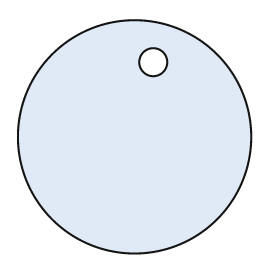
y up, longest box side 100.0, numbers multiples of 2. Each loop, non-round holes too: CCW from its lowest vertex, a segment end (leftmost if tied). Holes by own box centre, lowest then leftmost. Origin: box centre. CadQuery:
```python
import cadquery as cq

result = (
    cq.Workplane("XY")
    .moveTo(0.0, 0.0)
    .circle(50.0)
    .moveTo(8.0, 32.0)
    .circle(6.0)
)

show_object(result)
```